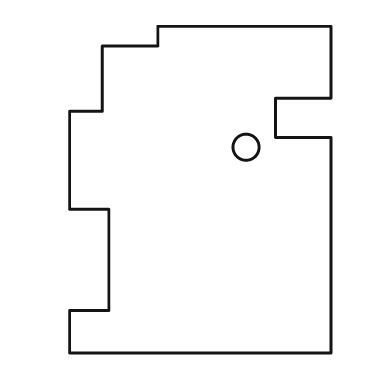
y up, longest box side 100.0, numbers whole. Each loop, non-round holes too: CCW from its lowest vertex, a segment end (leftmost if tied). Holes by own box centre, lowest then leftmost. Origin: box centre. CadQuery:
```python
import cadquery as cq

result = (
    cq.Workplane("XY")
    .moveTo(-40.0, -50.0)
    .lineTo(40.0, -50.0)
    .lineTo(40.0, 16.0)
    .lineTo(23.0, 16.0)
    .lineTo(23.0, 28.0)
    .lineTo(40.0, 28.0)
    .lineTo(40.0, 50.0)
    .lineTo(-13.0, 50.0)
    .lineTo(-13.0, 44.0)
    .lineTo(-30.0, 44.0)
    .lineTo(-30.0, 24.0)
    .lineTo(-40.0, 24.0)
    .lineTo(-40.0, -6.0)
    .lineTo(-28.0, -6.0)
    .lineTo(-28.0, -37.0)
    .lineTo(-40.0, -37.0)
    .close()
    .moveTo(14.0, 13.0)
    .circle(4.0)
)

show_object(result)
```